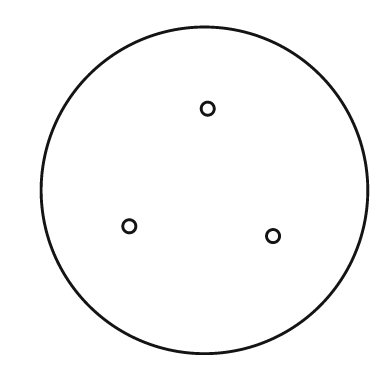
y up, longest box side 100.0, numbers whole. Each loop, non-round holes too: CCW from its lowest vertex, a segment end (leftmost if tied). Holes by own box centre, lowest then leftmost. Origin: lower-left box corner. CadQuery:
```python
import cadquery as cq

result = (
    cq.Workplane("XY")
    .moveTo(50.0, 50.0)
    .circle(50.0)
    .moveTo(71.0, 36.0)
    .circle(2.0)
    .moveTo(27.0, 39.0)
    .circle(2.0)
    .moveTo(51.0, 75.0)
    .circle(2.0)
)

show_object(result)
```